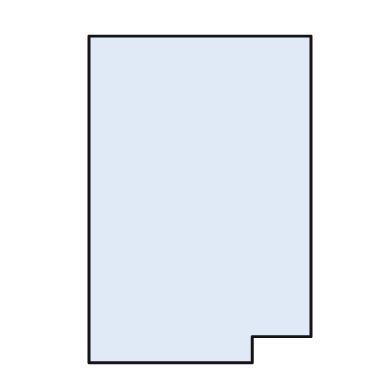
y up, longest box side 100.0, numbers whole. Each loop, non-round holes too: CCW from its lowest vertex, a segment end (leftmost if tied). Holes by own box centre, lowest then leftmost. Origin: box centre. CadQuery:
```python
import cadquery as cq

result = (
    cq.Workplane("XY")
    .moveTo(-34.0, -50.0)
    .lineTo(16.0, -50.0)
    .lineTo(16.0, -42.0)
    .lineTo(34.0, -42.0)
    .lineTo(34.0, 50.0)
    .lineTo(-34.0, 50.0)
    .close()
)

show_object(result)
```